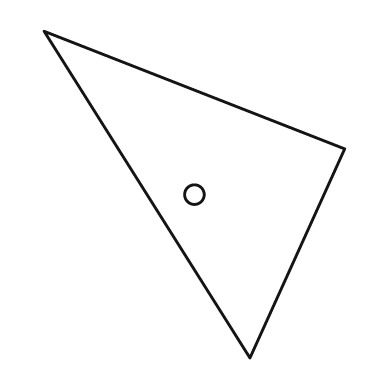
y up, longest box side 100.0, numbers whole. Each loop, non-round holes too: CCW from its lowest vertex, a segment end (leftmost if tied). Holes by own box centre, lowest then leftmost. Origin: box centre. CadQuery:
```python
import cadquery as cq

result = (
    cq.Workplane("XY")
    .moveTo(17.0, -50.0)
    .lineTo(46.0, 14.0)
    .lineTo(-46.0, 50.0)
    .close()
    .moveTo(0.0, 0.0)
    .circle(3.0)
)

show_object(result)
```